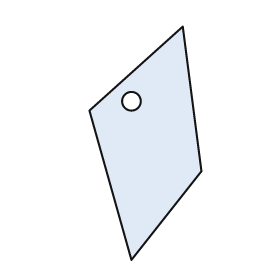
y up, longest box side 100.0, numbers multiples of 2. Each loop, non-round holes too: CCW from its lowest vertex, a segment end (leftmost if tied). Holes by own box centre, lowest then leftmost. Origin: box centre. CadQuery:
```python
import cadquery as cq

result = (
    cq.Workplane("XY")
    .moveTo(-6.0, -50.0)
    .lineTo(24.0, -12.0)
    .lineTo(16.0, 50.0)
    .lineTo(-24.0, 14.0)
    .close()
    .moveTo(-6.0, 18.0)
    .circle(4.0)
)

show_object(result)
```